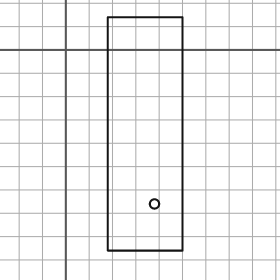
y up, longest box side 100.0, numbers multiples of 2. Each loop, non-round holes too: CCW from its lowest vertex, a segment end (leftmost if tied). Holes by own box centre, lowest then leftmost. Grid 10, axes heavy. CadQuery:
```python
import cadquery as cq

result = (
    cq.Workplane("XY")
    .moveTo(18.0, -86.0)
    .lineTo(50.0, -86.0)
    .lineTo(50.0, 14.0)
    .lineTo(18.0, 14.0)
    .close()
    .moveTo(38.0, -66.0)
    .circle(2.0)
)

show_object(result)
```